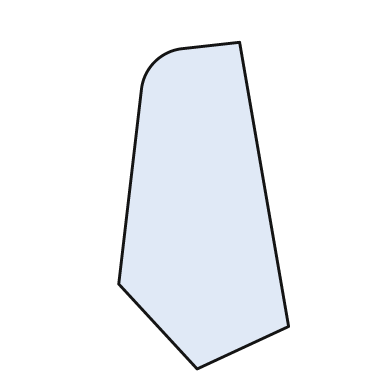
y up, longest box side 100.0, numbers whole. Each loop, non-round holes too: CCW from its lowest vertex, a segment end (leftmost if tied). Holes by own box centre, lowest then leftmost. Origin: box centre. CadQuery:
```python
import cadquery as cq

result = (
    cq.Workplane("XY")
    .moveTo(-2.0, -50.0)
    .lineTo(26.0, -37.0)
    .lineTo(11.0, 50.0)
    .lineTo(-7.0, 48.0)
    .threePointArc((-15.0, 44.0), (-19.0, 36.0))
    .lineTo(-26.0, -24.0)
    .close()
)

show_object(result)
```